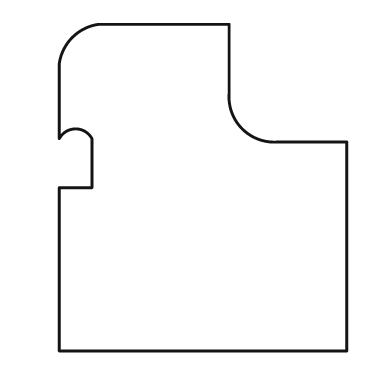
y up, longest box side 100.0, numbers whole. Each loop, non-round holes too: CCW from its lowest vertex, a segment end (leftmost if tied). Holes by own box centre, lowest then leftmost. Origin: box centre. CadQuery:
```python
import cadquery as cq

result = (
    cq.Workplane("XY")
    .moveTo(-44.0, -50.0)
    .lineTo(44.0, -50.0)
    .lineTo(44.0, 14.0)
    .lineTo(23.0, 14.0)
    .threePointArc((12.0, 18.0), (8.0, 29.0))
    .lineTo(8.0, 50.0)
    .lineTo(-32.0, 50.0)
    .threePointArc((-40.0, 46.0), (-44.0, 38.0))
    .lineTo(-44.0, 15.0)
    .threePointArc((-39.0, 18.0), (-34.0, 15.0))
    .lineTo(-34.0, 0.0)
    .lineTo(-44.0, 0.0)
    .close()
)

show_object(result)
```